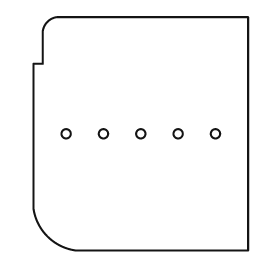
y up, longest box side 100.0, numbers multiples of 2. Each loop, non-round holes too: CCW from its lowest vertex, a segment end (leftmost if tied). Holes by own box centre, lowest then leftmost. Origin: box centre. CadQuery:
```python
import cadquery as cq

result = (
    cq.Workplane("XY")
    .moveTo(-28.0, -50.0)
    .lineTo(46.0, -50.0)
    .lineTo(46.0, 50.0)
    .lineTo(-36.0, 50.0)
    .threePointArc((-40.0, 48.0), (-42.0, 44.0))
    .lineTo(-42.0, 30.0)
    .lineTo(-46.0, 30.0)
    .lineTo(-46.0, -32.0)
    .threePointArc((-40.0, -44.0), (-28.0, -50.0))
    .close()
    .moveTo(-32.0, 0.0)
    .circle(2.0)
    .moveTo(-16.0, 0.0)
    .circle(2.0)
    .moveTo(0.0, 0.0)
    .circle(2.0)
    .moveTo(16.0, 0.0)
    .circle(2.0)
    .moveTo(32.0, 0.0)
    .circle(2.0)
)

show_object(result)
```